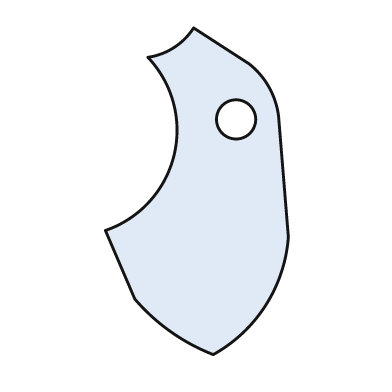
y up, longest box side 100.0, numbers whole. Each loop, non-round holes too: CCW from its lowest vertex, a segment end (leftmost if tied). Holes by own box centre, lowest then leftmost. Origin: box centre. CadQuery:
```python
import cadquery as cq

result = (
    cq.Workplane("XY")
    .moveTo(5.0, -50.0)
    .threePointArc((21.0, -35.0), (28.0, -14.0))
    .lineTo(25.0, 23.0)
    .threePointArc((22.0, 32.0), (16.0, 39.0))
    .lineTo(-1.0, 50.0)
    .threePointArc((-7.0, 44.0), (-15.0, 41.0))
    .threePointArc((-7.0, 11.0), (-28.0, -12.0))
    .lineTo(-19.0, -33.0)
    .threePointArc((-8.0, -43.0), (5.0, -50.0))
    .close()
    .moveTo(12.0, 22.0)
    .circle(6.0)
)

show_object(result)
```